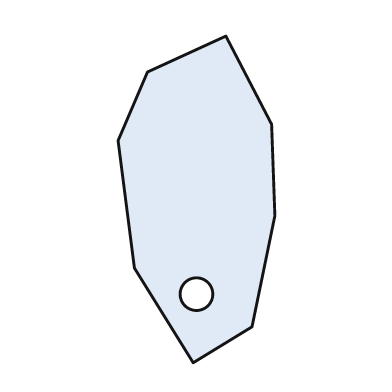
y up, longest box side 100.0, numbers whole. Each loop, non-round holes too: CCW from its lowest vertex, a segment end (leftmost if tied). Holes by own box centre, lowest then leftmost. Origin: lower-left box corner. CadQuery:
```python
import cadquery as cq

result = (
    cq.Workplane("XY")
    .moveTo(23.0, 0.0)
    .lineTo(41.0, 11.0)
    .lineTo(48.0, 45.0)
    .lineTo(47.0, 73.0)
    .lineTo(33.0, 100.0)
    .lineTo(9.0, 89.0)
    .lineTo(0.0, 68.0)
    .lineTo(5.0, 29.0)
    .close()
    .moveTo(24.0, 21.0)
    .circle(5.0)
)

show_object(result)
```